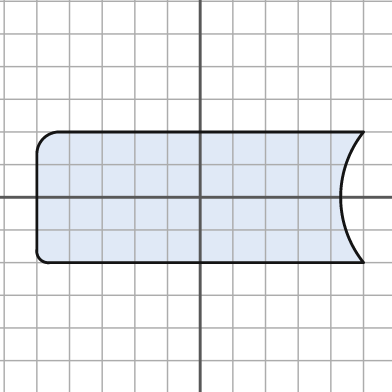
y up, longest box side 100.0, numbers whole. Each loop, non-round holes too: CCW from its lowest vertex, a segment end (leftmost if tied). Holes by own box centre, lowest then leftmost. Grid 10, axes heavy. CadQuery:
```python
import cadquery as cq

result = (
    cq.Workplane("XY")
    .moveTo(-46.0, -20.0)
    .lineTo(50.0, -20.0)
    .threePointArc((43.0, 0.0), (50.0, 20.0))
    .lineTo(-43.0, 20.0)
    .threePointArc((-48.0, 18.0), (-50.0, 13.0))
    .lineTo(-50.0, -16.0)
    .threePointArc((-49.0, -19.0), (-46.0, -20.0))
    .close()
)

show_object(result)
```